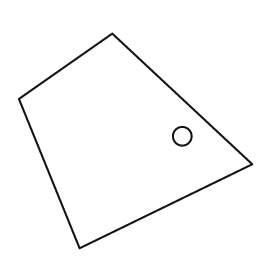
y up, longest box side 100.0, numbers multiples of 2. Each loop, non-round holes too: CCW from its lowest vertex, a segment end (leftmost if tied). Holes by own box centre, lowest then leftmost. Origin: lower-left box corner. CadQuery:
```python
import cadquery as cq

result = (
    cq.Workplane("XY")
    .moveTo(26.0, 0.0)
    .lineTo(100.0, 36.0)
    .lineTo(40.0, 92.0)
    .lineTo(0.0, 64.0)
    .close()
    .moveTo(70.0, 48.0)
    .circle(4.0)
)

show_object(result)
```